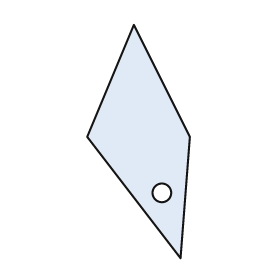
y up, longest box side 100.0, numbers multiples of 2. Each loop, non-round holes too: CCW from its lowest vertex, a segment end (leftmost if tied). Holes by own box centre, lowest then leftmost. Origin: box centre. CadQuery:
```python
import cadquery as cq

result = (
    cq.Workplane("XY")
    .moveTo(18.0, -50.0)
    .lineTo(22.0, 2.0)
    .lineTo(-2.0, 50.0)
    .lineTo(-22.0, 2.0)
    .close()
    .moveTo(10.0, -22.0)
    .circle(4.0)
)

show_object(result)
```